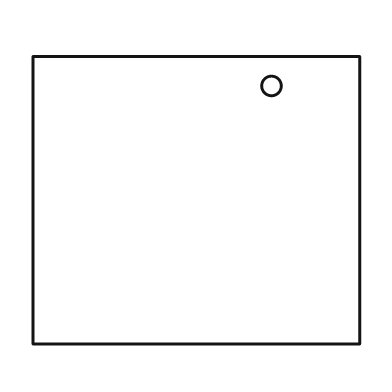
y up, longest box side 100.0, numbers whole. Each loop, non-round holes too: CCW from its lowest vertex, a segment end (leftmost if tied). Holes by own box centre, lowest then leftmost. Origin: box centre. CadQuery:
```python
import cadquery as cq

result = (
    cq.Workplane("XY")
    .moveTo(-50.0, -44.0)
    .lineTo(50.0, -44.0)
    .lineTo(50.0, 44.0)
    .lineTo(-50.0, 44.0)
    .close()
    .moveTo(23.0, 35.0)
    .circle(3.0)
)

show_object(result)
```